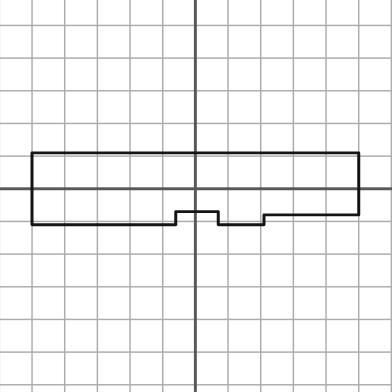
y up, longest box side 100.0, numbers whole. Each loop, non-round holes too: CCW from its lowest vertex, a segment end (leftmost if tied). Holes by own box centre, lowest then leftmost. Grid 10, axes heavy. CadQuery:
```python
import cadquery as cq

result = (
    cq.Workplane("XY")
    .moveTo(-50.0, -11.0)
    .lineTo(-6.0, -11.0)
    .lineTo(-6.0, -7.0)
    .lineTo(7.0, -7.0)
    .lineTo(7.0, -11.0)
    .lineTo(21.0, -11.0)
    .lineTo(21.0, -8.0)
    .lineTo(50.0, -8.0)
    .lineTo(50.0, 11.0)
    .lineTo(-50.0, 11.0)
    .close()
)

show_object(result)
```